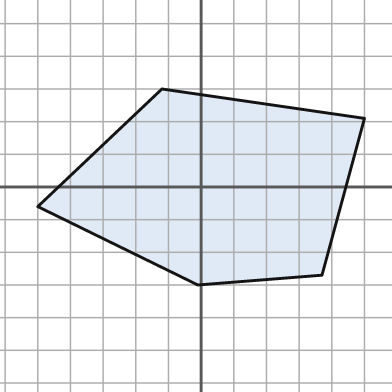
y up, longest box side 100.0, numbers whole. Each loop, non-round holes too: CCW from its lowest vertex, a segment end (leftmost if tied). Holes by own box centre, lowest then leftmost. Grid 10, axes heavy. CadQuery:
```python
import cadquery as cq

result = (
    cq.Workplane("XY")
    .moveTo(-1.0, -30.0)
    .lineTo(37.0, -27.0)
    .lineTo(50.0, 21.0)
    .lineTo(-12.0, 30.0)
    .lineTo(-50.0, -6.0)
    .close()
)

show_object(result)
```